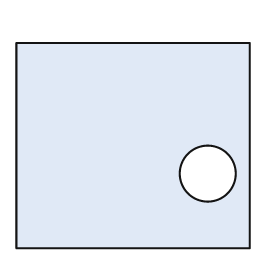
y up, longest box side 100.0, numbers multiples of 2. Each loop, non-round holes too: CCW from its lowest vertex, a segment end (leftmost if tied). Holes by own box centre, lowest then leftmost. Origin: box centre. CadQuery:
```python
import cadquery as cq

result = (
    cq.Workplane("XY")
    .moveTo(-50.0, -44.0)
    .lineTo(50.0, -44.0)
    .lineTo(50.0, 44.0)
    .lineTo(-50.0, 44.0)
    .close()
    .moveTo(32.0, -12.0)
    .circle(12.0)
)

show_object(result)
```